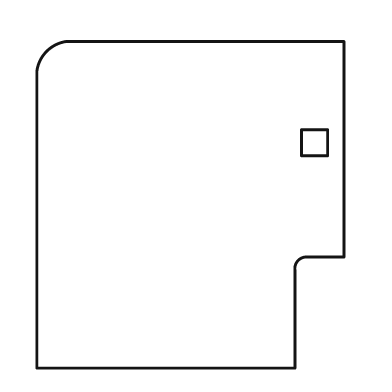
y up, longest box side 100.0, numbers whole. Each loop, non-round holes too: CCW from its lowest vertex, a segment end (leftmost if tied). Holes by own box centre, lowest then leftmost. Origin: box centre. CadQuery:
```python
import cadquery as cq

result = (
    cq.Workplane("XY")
    .moveTo(-47.0, -50.0)
    .lineTo(32.0, -50.0)
    .lineTo(32.0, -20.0)
    .threePointArc((33.0, -17.0), (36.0, -16.0))
    .lineTo(47.0, -16.0)
    .lineTo(47.0, 50.0)
    .lineTo(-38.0, 50.0)
    .threePointArc((-44.0, 47.0), (-47.0, 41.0))
    .close()
    .moveTo(34.0, 15.0)
    .lineTo(42.0, 15.0)
    .lineTo(42.0, 23.0)
    .lineTo(34.0, 23.0)
    .close()
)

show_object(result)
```